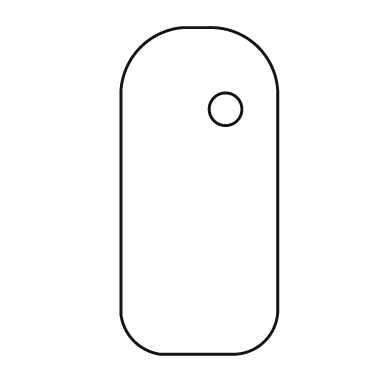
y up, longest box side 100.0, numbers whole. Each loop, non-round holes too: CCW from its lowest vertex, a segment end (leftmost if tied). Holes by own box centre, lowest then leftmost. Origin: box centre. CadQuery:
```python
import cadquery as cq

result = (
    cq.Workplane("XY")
    .moveTo(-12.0, -50.0)
    .lineTo(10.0, -50.0)
    .threePointArc((20.0, -46.0), (24.0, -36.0))
    .lineTo(24.0, 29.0)
    .threePointArc((18.0, 44.0), (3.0, 50.0))
    .lineTo(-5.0, 50.0)
    .threePointArc((-18.0, 44.0), (-24.0, 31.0))
    .lineTo(-24.0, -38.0)
    .threePointArc((-20.0, -46.0), (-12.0, -50.0))
    .close()
    .moveTo(8.0, 25.0)
    .circle(5.0)
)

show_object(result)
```